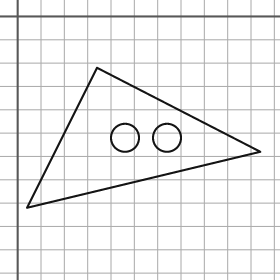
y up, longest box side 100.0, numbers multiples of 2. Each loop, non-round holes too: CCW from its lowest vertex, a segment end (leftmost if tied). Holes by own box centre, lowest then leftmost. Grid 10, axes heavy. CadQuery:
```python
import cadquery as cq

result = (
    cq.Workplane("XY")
    .moveTo(4.0, -82.0)
    .lineTo(104.0, -58.0)
    .lineTo(34.0, -22.0)
    .close()
    .moveTo(46.0, -52.0)
    .circle(6.0)
    .moveTo(64.0, -52.0)
    .circle(6.0)
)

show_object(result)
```